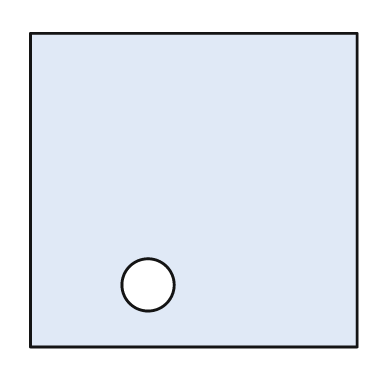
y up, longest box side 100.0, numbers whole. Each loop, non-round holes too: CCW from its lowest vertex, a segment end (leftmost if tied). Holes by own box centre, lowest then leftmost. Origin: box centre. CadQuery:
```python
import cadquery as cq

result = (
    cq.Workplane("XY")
    .moveTo(-50.0, -48.0)
    .lineTo(50.0, -48.0)
    .lineTo(50.0, 48.0)
    .lineTo(-50.0, 48.0)
    .close()
    .moveTo(-14.0, -29.0)
    .circle(8.0)
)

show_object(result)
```